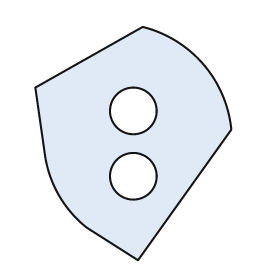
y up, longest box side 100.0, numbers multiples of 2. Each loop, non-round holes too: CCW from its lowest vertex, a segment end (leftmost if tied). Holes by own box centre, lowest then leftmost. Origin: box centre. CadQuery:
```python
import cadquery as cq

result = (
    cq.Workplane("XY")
    .moveTo(2.0, -50.0)
    .lineTo(42.0, 6.0)
    .threePointArc((30.0, 34.0), (4.0, 50.0))
    .lineTo(-42.0, 24.0)
    .lineTo(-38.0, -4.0)
    .threePointArc((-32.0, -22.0), (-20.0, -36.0))
    .close()
    .moveTo(0.0, -14.0)
    .circle(10.0)
    .moveTo(0.0, 14.0)
    .circle(10.0)
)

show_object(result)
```